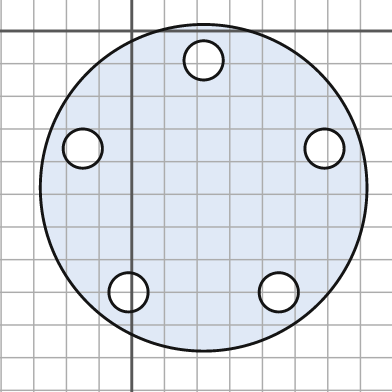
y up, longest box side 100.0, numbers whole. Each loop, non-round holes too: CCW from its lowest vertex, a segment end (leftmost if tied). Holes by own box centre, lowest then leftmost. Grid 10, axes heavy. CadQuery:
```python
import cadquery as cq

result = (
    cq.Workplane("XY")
    .moveTo(22.0, -48.0)
    .circle(50.0)
    .moveTo(-1.0, -80.0)
    .circle(6.0)
    .moveTo(45.0, -80.0)
    .circle(6.0)
    .moveTo(-15.0, -36.0)
    .circle(6.0)
    .moveTo(59.0, -36.0)
    .circle(6.0)
    .moveTo(22.0, -9.0)
    .circle(6.0)
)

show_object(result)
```